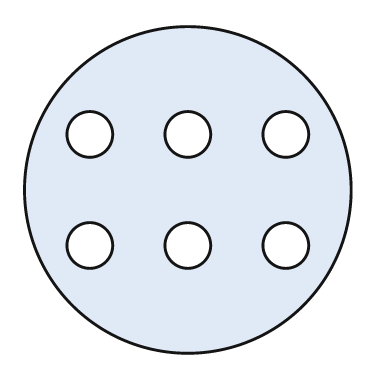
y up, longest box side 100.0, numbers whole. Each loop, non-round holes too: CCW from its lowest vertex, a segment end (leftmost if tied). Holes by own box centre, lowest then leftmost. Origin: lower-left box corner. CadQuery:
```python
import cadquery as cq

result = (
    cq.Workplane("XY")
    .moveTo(50.0, 50.0)
    .circle(50.0)
    .moveTo(20.0, 33.0)
    .circle(7.0)
    .moveTo(50.0, 33.0)
    .circle(7.0)
    .moveTo(80.0, 33.0)
    .circle(7.0)
    .moveTo(20.0, 67.0)
    .circle(7.0)
    .moveTo(50.0, 67.0)
    .circle(7.0)
    .moveTo(80.0, 67.0)
    .circle(7.0)
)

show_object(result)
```